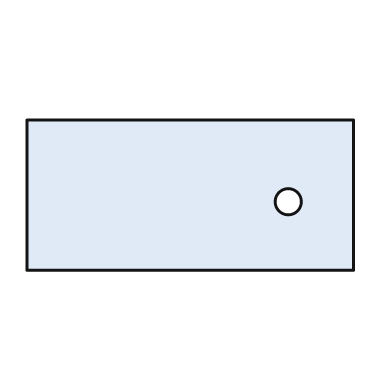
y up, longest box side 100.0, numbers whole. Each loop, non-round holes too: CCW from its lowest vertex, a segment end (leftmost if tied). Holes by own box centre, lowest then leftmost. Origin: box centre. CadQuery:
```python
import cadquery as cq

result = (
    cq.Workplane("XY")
    .moveTo(-50.0, -23.0)
    .lineTo(50.0, -23.0)
    .lineTo(50.0, 23.0)
    .lineTo(-50.0, 23.0)
    .close()
    .moveTo(30.0, -2.0)
    .circle(4.0)
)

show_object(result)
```